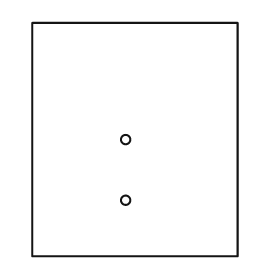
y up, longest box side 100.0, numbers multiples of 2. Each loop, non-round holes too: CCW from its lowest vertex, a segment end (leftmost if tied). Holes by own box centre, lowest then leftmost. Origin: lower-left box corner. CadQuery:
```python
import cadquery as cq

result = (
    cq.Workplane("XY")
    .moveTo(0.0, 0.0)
    .lineTo(88.0, 0.0)
    .lineTo(88.0, 100.0)
    .lineTo(0.0, 100.0)
    .close()
    .moveTo(40.0, 24.0)
    .circle(2.0)
    .moveTo(40.0, 50.0)
    .circle(2.0)
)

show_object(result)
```